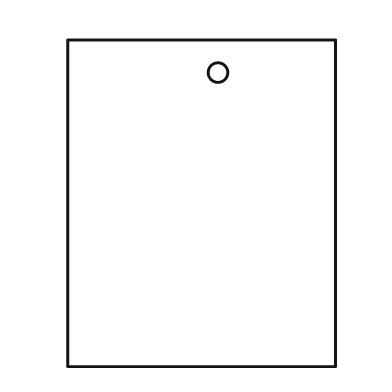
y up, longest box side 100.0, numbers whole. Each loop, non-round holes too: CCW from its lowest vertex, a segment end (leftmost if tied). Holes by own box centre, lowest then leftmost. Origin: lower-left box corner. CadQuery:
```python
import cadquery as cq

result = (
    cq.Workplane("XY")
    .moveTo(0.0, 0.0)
    .lineTo(82.0, 0.0)
    .lineTo(82.0, 100.0)
    .lineTo(0.0, 100.0)
    .close()
    .moveTo(46.0, 90.0)
    .circle(3.0)
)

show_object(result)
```